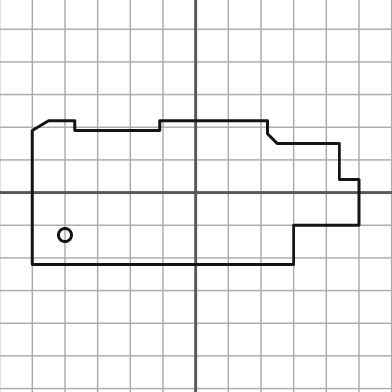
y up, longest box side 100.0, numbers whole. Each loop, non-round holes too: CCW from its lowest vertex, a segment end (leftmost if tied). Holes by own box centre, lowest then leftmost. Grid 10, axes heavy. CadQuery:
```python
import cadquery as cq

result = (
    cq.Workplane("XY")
    .moveTo(-50.0, -22.0)
    .lineTo(30.0, -22.0)
    .lineTo(30.0, -10.0)
    .lineTo(50.0, -10.0)
    .lineTo(50.0, 4.0)
    .lineTo(44.0, 4.0)
    .lineTo(44.0, 15.0)
    .lineTo(25.0, 15.0)
    .lineTo(22.0, 18.0)
    .lineTo(22.0, 22.0)
    .lineTo(-11.0, 22.0)
    .lineTo(-11.0, 19.0)
    .lineTo(-37.0, 19.0)
    .lineTo(-37.0, 22.0)
    .lineTo(-45.0, 22.0)
    .lineTo(-50.0, 19.0)
    .close()
    .moveTo(-40.0, -13.0)
    .circle(2.0)
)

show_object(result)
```